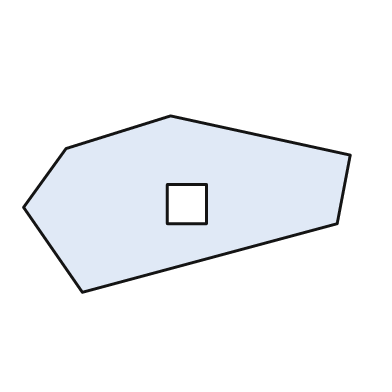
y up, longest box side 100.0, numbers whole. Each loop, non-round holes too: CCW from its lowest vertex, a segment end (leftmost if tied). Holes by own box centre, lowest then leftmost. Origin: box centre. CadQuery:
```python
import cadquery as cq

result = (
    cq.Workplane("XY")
    .moveTo(-32.0, -27.0)
    .lineTo(46.0, -6.0)
    .lineTo(50.0, 15.0)
    .lineTo(-5.0, 27.0)
    .lineTo(-37.0, 17.0)
    .lineTo(-50.0, -1.0)
    .close()
    .moveTo(-6.0, -6.0)
    .lineTo(6.0, -6.0)
    .lineTo(6.0, 6.0)
    .lineTo(-6.0, 6.0)
    .close()
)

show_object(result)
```